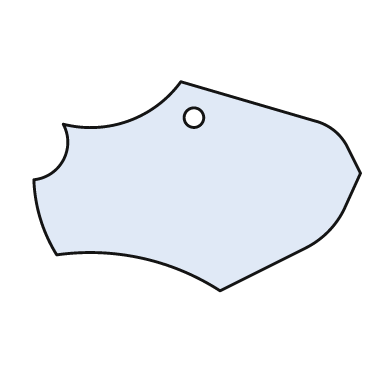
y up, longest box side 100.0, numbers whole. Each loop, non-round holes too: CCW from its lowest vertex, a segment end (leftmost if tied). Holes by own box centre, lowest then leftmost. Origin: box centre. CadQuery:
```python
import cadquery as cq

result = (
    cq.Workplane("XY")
    .moveTo(7.0, -32.0)
    .lineTo(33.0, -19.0)
    .threePointArc((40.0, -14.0), (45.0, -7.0))
    .lineTo(50.0, 4.0)
    .lineTo(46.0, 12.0)
    .threePointArc((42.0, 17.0), (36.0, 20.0))
    .lineTo(-5.0, 32.0)
    .threePointArc((-21.0, 20.0), (-41.0, 19.0))
    .threePointArc((-41.0, 8.0), (-50.0, 2.0))
    .threePointArc((-48.0, -10.0), (-43.0, -21.0))
    .threePointArc((-17.0, -22.0), (7.0, -32.0))
    .close()
    .moveTo(-1.0, 21.0)
    .circle(3.0)
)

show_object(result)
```